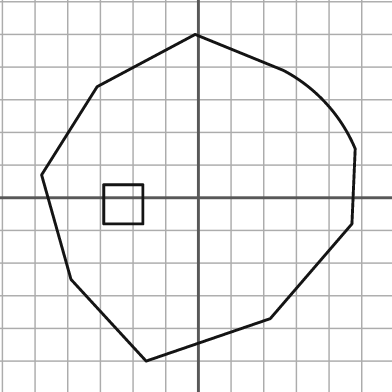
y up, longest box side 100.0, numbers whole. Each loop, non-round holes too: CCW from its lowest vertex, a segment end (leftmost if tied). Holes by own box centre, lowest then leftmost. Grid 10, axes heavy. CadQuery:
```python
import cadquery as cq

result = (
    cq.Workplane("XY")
    .moveTo(-16.0, -50.0)
    .lineTo(22.0, -37.0)
    .lineTo(47.0, -8.0)
    .lineTo(48.0, 15.0)
    .threePointArc((39.0, 29.0), (26.0, 39.0))
    .lineTo(-1.0, 50.0)
    .lineTo(-31.0, 34.0)
    .lineTo(-48.0, 7.0)
    .lineTo(-39.0, -25.0)
    .close()
    .moveTo(-29.0, -8.0)
    .lineTo(-17.0, -8.0)
    .lineTo(-17.0, 4.0)
    .lineTo(-29.0, 4.0)
    .close()
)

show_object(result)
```